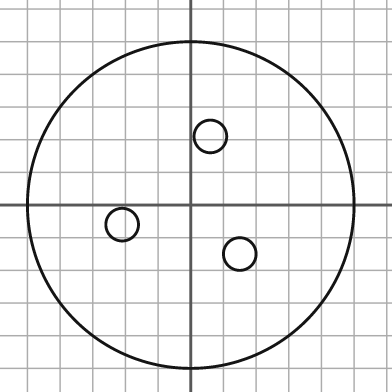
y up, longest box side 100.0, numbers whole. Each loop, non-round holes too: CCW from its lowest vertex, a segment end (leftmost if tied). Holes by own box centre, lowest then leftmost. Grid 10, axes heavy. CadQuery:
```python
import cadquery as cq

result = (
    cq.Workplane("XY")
    .moveTo(0.0, 0.0)
    .circle(50.0)
    .moveTo(15.0, -15.0)
    .circle(5.0)
    .moveTo(-21.0, -6.0)
    .circle(5.0)
    .moveTo(6.0, 21.0)
    .circle(5.0)
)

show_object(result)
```